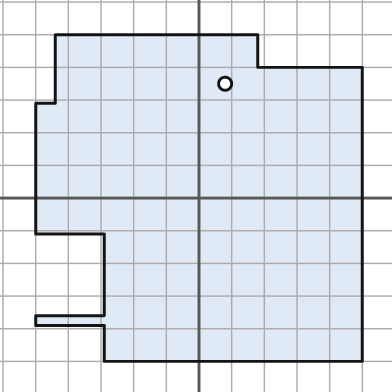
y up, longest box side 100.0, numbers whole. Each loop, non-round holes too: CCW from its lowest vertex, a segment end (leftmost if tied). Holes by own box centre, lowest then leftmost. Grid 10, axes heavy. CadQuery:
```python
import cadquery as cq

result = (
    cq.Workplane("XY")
    .moveTo(-29.0, -50.0)
    .lineTo(50.0, -50.0)
    .lineTo(50.0, 40.0)
    .lineTo(18.0, 40.0)
    .lineTo(18.0, 50.0)
    .lineTo(-44.0, 50.0)
    .lineTo(-44.0, 29.0)
    .lineTo(-50.0, 29.0)
    .lineTo(-50.0, -11.0)
    .lineTo(-29.0, -11.0)
    .lineTo(-29.0, -36.0)
    .lineTo(-50.0, -36.0)
    .lineTo(-50.0, -39.0)
    .lineTo(-29.0, -39.0)
    .close()
    .moveTo(8.0, 35.0)
    .circle(2.0)
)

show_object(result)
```